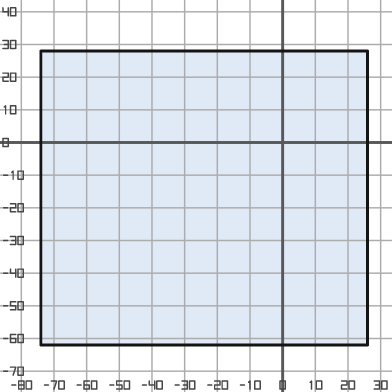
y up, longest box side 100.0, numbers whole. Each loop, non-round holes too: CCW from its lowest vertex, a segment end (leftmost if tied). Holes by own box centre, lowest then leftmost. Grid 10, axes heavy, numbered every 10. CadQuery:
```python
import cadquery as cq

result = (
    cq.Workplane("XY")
    .moveTo(-74.0, -62.0)
    .lineTo(26.0, -62.0)
    .lineTo(26.0, 28.0)
    .lineTo(-74.0, 28.0)
    .close()
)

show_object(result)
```